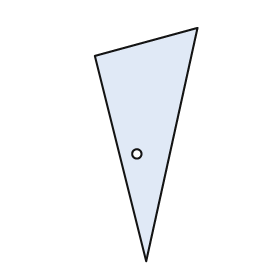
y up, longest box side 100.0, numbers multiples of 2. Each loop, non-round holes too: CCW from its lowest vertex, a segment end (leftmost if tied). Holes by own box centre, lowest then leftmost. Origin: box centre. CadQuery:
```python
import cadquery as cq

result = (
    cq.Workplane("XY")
    .moveTo(0.0, -50.0)
    .lineTo(22.0, 50.0)
    .lineTo(-22.0, 38.0)
    .close()
    .moveTo(-4.0, -4.0)
    .circle(2.0)
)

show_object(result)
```